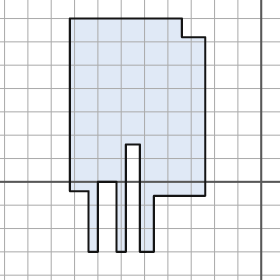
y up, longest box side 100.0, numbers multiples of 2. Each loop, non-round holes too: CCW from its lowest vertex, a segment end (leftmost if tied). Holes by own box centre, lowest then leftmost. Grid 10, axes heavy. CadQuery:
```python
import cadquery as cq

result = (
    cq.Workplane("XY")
    .moveTo(-74.0, -30.0)
    .lineTo(-70.0, -30.0)
    .lineTo(-70.0, 0.0)
    .lineTo(-62.0, 0.0)
    .lineTo(-62.0, -30.0)
    .lineTo(-58.0, -30.0)
    .lineTo(-58.0, 16.0)
    .lineTo(-52.0, 16.0)
    .lineTo(-52.0, -30.0)
    .lineTo(-46.0, -30.0)
    .lineTo(-46.0, -6.0)
    .lineTo(-24.0, -6.0)
    .lineTo(-24.0, 62.0)
    .lineTo(-34.0, 62.0)
    .lineTo(-34.0, 70.0)
    .lineTo(-82.0, 70.0)
    .lineTo(-82.0, -4.0)
    .lineTo(-74.0, -4.0)
    .close()
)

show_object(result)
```